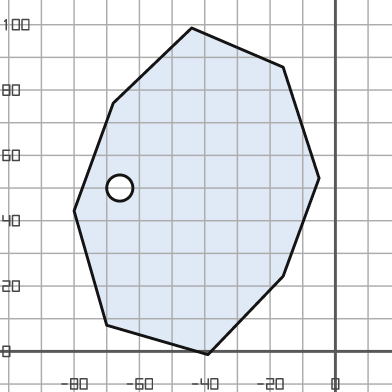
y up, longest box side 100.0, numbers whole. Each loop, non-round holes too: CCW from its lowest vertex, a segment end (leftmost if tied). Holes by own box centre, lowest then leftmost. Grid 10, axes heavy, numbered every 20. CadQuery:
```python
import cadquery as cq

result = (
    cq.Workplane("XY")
    .moveTo(-39.0, -1.0)
    .lineTo(-16.0, 23.0)
    .lineTo(-5.0, 53.0)
    .lineTo(-16.0, 87.0)
    .lineTo(-44.0, 99.0)
    .lineTo(-68.0, 76.0)
    .lineTo(-80.0, 43.0)
    .lineTo(-70.0, 8.0)
    .close()
    .moveTo(-66.0, 50.0)
    .circle(4.0)
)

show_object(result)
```